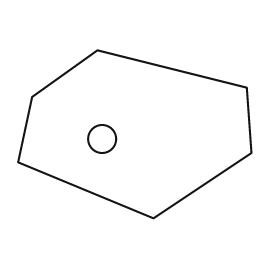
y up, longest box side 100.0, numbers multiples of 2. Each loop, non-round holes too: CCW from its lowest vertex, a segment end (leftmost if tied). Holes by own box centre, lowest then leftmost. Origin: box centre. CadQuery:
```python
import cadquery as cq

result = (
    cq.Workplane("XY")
    .moveTo(8.0, -36.0)
    .lineTo(50.0, -8.0)
    .lineTo(48.0, 20.0)
    .lineTo(-16.0, 36.0)
    .lineTo(-44.0, 16.0)
    .lineTo(-50.0, -12.0)
    .close()
    .moveTo(-14.0, -2.0)
    .circle(6.0)
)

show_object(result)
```